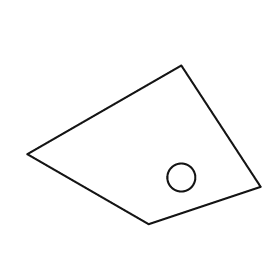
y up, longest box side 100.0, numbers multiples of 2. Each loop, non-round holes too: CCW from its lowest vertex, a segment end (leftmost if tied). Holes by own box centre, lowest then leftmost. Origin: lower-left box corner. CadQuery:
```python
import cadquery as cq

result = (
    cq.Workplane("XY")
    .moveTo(52.0, 0.0)
    .lineTo(100.0, 16.0)
    .lineTo(66.0, 68.0)
    .lineTo(0.0, 30.0)
    .close()
    .moveTo(66.0, 20.0)
    .circle(6.0)
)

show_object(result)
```